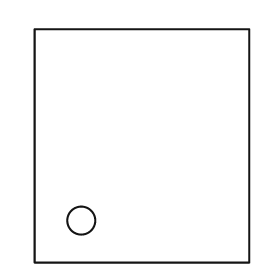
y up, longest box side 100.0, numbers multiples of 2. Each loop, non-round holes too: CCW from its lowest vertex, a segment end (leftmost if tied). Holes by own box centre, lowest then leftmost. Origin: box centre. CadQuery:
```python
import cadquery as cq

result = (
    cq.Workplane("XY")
    .moveTo(-46.0, -50.0)
    .lineTo(46.0, -50.0)
    .lineTo(46.0, 50.0)
    .lineTo(-46.0, 50.0)
    .close()
    .moveTo(-26.0, -32.0)
    .circle(6.0)
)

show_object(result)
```